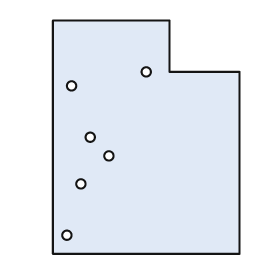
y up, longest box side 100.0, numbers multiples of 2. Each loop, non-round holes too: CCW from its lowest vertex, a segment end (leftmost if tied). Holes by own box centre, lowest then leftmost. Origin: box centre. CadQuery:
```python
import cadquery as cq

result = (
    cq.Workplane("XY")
    .moveTo(-40.0, -50.0)
    .lineTo(40.0, -50.0)
    .lineTo(40.0, 28.0)
    .lineTo(10.0, 28.0)
    .lineTo(10.0, 50.0)
    .lineTo(-40.0, 50.0)
    .close()
    .moveTo(-34.0, -42.0)
    .circle(2.0)
    .moveTo(-28.0, -20.0)
    .circle(2.0)
    .moveTo(-16.0, -8.0)
    .circle(2.0)
    .moveTo(-24.0, 0.0)
    .circle(2.0)
    .moveTo(-32.0, 22.0)
    .circle(2.0)
    .moveTo(0.0, 28.0)
    .circle(2.0)
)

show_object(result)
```